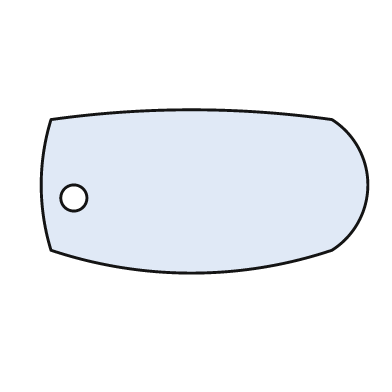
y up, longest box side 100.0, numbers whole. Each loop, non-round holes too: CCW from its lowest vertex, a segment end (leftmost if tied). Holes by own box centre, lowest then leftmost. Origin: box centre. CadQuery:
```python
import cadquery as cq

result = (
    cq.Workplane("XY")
    .moveTo(-47.0, -18.0)
    .threePointArc((-4.0, -25.0), (39.0, -18.0))
    .threePointArc((50.0, 2.0), (39.0, 22.0))
    .threePointArc((-4.0, 25.0), (-47.0, 22.0))
    .threePointArc((-50.0, 2.0), (-47.0, -18.0))
    .close()
    .moveTo(-40.0, -2.0)
    .circle(4.0)
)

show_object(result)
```